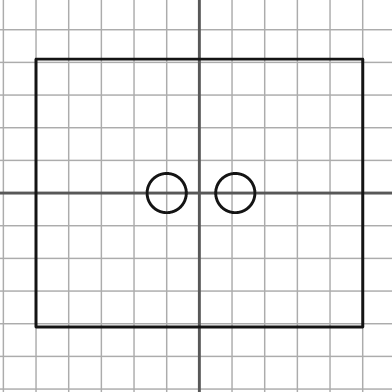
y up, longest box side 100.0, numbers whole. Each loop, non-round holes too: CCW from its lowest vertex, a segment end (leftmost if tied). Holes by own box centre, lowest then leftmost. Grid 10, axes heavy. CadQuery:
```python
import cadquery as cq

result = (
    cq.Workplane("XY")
    .moveTo(-50.0, -41.0)
    .lineTo(50.0, -41.0)
    .lineTo(50.0, 41.0)
    .lineTo(-50.0, 41.0)
    .close()
    .moveTo(-10.0, 0.0)
    .circle(6.0)
    .moveTo(11.0, 0.0)
    .circle(6.0)
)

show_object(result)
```